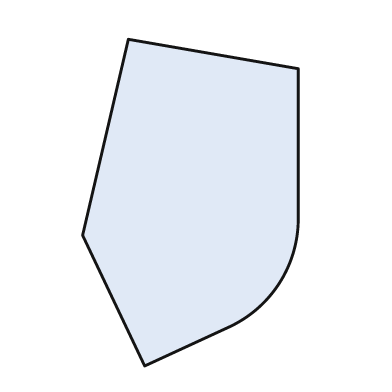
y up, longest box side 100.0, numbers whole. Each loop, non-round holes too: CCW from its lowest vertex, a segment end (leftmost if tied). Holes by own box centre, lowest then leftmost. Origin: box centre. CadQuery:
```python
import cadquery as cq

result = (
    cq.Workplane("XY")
    .moveTo(-14.0, -50.0)
    .lineTo(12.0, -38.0)
    .threePointArc((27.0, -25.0), (33.0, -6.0))
    .lineTo(33.0, 41.0)
    .lineTo(-19.0, 50.0)
    .lineTo(-33.0, -10.0)
    .close()
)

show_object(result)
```